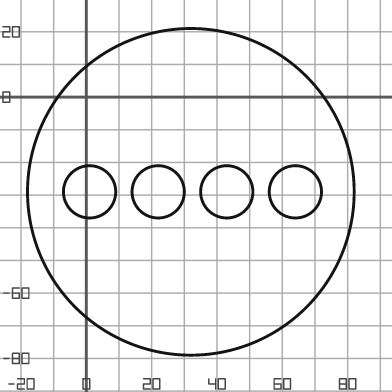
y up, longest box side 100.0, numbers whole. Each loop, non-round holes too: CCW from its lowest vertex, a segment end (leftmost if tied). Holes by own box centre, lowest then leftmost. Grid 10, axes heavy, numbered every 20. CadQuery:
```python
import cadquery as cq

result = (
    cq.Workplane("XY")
    .moveTo(32.0, -29.0)
    .circle(50.0)
    .moveTo(1.0, -29.0)
    .circle(8.0)
    .moveTo(22.0, -29.0)
    .circle(8.0)
    .moveTo(43.0, -29.0)
    .circle(8.0)
    .moveTo(64.0, -29.0)
    .circle(8.0)
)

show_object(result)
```